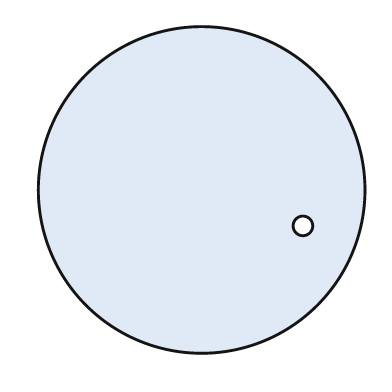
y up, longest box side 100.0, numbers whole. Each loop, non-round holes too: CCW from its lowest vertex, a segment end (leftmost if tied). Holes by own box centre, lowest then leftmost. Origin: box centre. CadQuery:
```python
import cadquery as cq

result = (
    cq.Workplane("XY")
    .moveTo(0.0, 0.0)
    .circle(50.0)
    .moveTo(31.0, -11.0)
    .circle(3.0)
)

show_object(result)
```